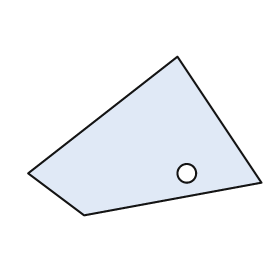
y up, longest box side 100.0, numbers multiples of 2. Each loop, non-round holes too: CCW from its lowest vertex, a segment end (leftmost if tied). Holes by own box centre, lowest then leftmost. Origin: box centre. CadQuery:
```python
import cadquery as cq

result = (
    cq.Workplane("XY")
    .moveTo(-26.0, -34.0)
    .lineTo(50.0, -20.0)
    .lineTo(14.0, 34.0)
    .lineTo(-50.0, -16.0)
    .close()
    .moveTo(18.0, -16.0)
    .circle(4.0)
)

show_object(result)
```